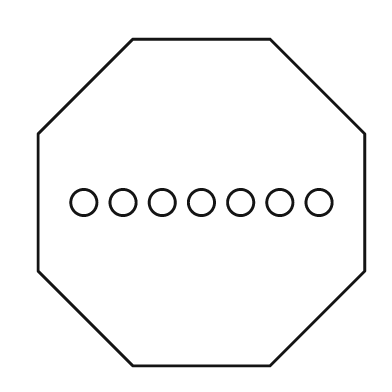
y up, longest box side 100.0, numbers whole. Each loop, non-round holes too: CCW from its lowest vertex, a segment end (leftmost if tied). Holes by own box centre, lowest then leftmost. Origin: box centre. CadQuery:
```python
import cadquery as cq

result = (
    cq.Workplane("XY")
    .moveTo(-21.0, -50.0)
    .lineTo(21.0, -50.0)
    .lineTo(50.0, -21.0)
    .lineTo(50.0, 21.0)
    .lineTo(21.0, 50.0)
    .lineTo(-21.0, 50.0)
    .lineTo(-50.0, 21.0)
    .lineTo(-50.0, -21.0)
    .close()
    .moveTo(-36.0, 0.0)
    .circle(4.0)
    .moveTo(-24.0, 0.0)
    .circle(4.0)
    .moveTo(-12.0, 0.0)
    .circle(4.0)
    .moveTo(0.0, 0.0)
    .circle(4.0)
    .moveTo(12.0, 0.0)
    .circle(4.0)
    .moveTo(24.0, 0.0)
    .circle(4.0)
    .moveTo(36.0, 0.0)
    .circle(4.0)
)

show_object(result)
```